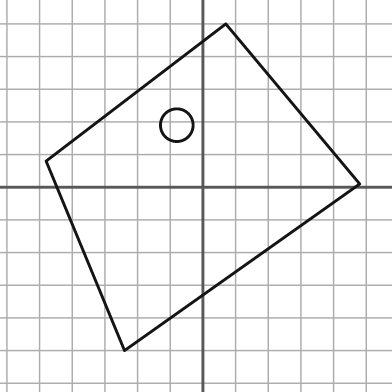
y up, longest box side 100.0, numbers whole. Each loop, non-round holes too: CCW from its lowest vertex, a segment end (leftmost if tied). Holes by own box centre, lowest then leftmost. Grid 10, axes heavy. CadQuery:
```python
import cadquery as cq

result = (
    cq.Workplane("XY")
    .moveTo(-24.0, -50.0)
    .lineTo(48.0, 1.0)
    .lineTo(7.0, 50.0)
    .lineTo(-48.0, 8.0)
    .close()
    .moveTo(-8.0, 19.0)
    .circle(5.0)
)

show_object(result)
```